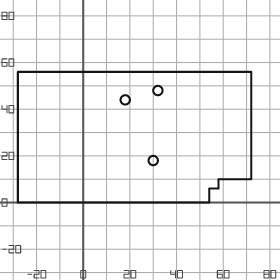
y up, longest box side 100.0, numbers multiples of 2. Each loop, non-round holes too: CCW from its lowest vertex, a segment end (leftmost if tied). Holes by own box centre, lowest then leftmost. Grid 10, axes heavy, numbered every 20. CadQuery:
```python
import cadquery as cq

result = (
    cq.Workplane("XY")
    .moveTo(-28.0, 0.0)
    .lineTo(54.0, 0.0)
    .lineTo(54.0, 6.0)
    .lineTo(58.0, 6.0)
    .lineTo(58.0, 10.0)
    .lineTo(72.0, 10.0)
    .lineTo(72.0, 56.0)
    .lineTo(-28.0, 56.0)
    .close()
    .moveTo(30.0, 18.0)
    .circle(2.0)
    .moveTo(18.0, 44.0)
    .circle(2.0)
    .moveTo(32.0, 48.0)
    .circle(2.0)
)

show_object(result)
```